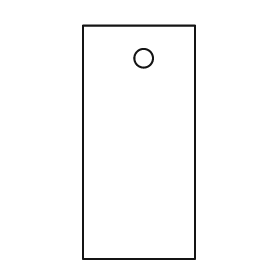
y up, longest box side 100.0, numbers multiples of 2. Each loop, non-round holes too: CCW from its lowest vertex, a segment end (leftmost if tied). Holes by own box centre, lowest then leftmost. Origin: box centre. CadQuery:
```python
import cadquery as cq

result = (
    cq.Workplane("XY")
    .moveTo(-24.0, -50.0)
    .lineTo(24.0, -50.0)
    .lineTo(24.0, 50.0)
    .lineTo(-24.0, 50.0)
    .close()
    .moveTo(2.0, 36.0)
    .circle(4.0)
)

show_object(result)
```